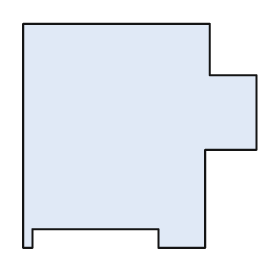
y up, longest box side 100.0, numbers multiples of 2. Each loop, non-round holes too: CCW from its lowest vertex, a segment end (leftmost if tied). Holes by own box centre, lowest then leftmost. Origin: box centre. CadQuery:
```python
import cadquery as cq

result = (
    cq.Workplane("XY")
    .moveTo(-50.0, -48.0)
    .lineTo(-46.0, -48.0)
    .lineTo(-46.0, -40.0)
    .lineTo(8.0, -40.0)
    .lineTo(8.0, -48.0)
    .lineTo(28.0, -48.0)
    .lineTo(28.0, -6.0)
    .lineTo(50.0, -6.0)
    .lineTo(50.0, 26.0)
    .lineTo(30.0, 26.0)
    .lineTo(30.0, 48.0)
    .lineTo(-50.0, 48.0)
    .close()
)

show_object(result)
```